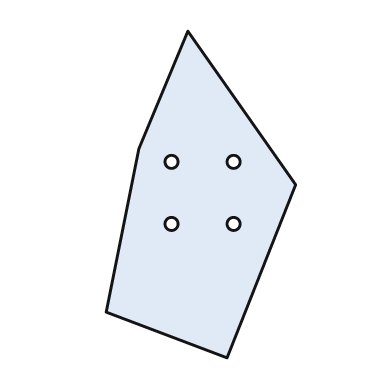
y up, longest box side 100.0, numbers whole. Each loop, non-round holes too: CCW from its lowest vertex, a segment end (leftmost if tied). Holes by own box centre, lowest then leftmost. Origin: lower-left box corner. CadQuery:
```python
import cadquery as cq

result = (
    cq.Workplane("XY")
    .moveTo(37.0, 0.0)
    .lineTo(58.0, 53.0)
    .lineTo(25.0, 100.0)
    .lineTo(10.0, 64.0)
    .lineTo(0.0, 14.0)
    .close()
    .moveTo(20.0, 41.0)
    .circle(2.0)
    .moveTo(39.0, 41.0)
    .circle(2.0)
    .moveTo(20.0, 60.0)
    .circle(2.0)
    .moveTo(39.0, 60.0)
    .circle(2.0)
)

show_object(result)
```